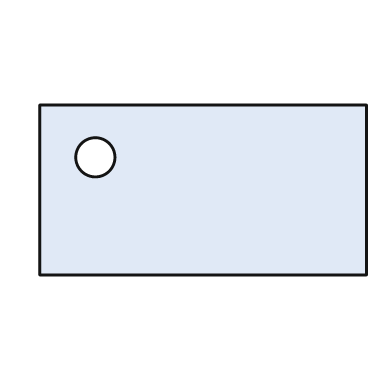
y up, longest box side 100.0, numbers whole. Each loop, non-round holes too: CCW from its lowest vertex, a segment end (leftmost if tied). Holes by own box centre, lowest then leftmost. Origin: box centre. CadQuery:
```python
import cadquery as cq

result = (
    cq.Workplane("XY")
    .moveTo(-50.0, -26.0)
    .lineTo(50.0, -26.0)
    .lineTo(50.0, 26.0)
    .lineTo(-50.0, 26.0)
    .close()
    .moveTo(-33.0, 10.0)
    .circle(6.0)
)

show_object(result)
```